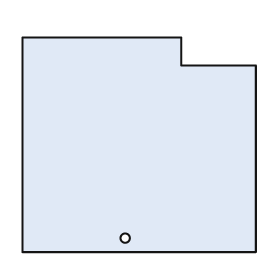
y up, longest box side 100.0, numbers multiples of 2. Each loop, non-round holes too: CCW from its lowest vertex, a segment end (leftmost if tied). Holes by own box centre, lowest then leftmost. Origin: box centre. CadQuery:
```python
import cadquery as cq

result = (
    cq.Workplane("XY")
    .moveTo(-50.0, -46.0)
    .lineTo(50.0, -46.0)
    .lineTo(50.0, 34.0)
    .lineTo(18.0, 34.0)
    .lineTo(18.0, 46.0)
    .lineTo(-50.0, 46.0)
    .close()
    .moveTo(-6.0, -40.0)
    .circle(2.0)
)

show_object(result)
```